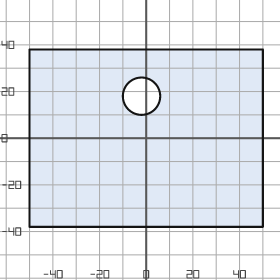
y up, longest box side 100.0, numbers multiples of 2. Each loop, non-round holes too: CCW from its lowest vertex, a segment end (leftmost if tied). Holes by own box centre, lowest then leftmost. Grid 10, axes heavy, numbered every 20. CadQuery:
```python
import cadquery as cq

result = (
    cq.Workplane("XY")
    .moveTo(-50.0, -38.0)
    .lineTo(50.0, -38.0)
    .lineTo(50.0, 38.0)
    .lineTo(-50.0, 38.0)
    .close()
    .moveTo(-2.0, 18.0)
    .circle(8.0)
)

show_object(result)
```